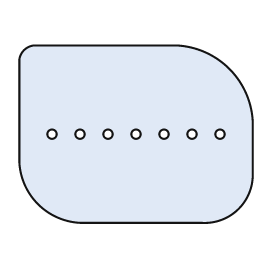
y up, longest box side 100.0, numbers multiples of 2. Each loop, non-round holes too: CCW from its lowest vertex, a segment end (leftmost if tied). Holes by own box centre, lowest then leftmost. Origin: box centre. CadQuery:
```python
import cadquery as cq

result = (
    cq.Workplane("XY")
    .moveTo(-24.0, -38.0)
    .lineTo(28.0, -38.0)
    .threePointArc((44.0, -32.0), (50.0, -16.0))
    .lineTo(50.0, 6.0)
    .threePointArc((40.0, 28.0), (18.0, 38.0))
    .lineTo(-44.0, 38.0)
    .threePointArc((-48.0, 36.0), (-50.0, 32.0))
    .lineTo(-50.0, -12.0)
    .threePointArc((-42.0, -30.0), (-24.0, -38.0))
    .close()
    .moveTo(-36.0, 0.0)
    .circle(2.0)
    .moveTo(-24.0, 0.0)
    .circle(2.0)
    .moveTo(-12.0, 0.0)
    .circle(2.0)
    .moveTo(0.0, 0.0)
    .circle(2.0)
    .moveTo(12.0, 0.0)
    .circle(2.0)
    .moveTo(24.0, 0.0)
    .circle(2.0)
    .moveTo(36.0, 0.0)
    .circle(2.0)
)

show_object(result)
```